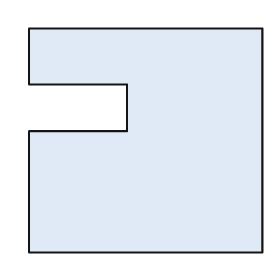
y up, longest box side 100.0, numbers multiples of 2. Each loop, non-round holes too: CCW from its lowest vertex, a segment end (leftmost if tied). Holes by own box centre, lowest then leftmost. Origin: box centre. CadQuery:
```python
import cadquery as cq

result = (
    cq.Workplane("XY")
    .moveTo(-50.0, -48.0)
    .lineTo(50.0, -48.0)
    .lineTo(50.0, 48.0)
    .lineTo(-50.0, 48.0)
    .lineTo(-50.0, 24.0)
    .lineTo(-8.0, 24.0)
    .lineTo(-8.0, 4.0)
    .lineTo(-50.0, 4.0)
    .close()
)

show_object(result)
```